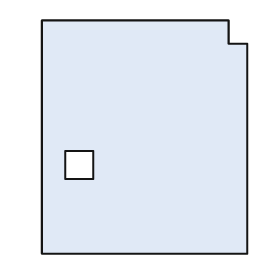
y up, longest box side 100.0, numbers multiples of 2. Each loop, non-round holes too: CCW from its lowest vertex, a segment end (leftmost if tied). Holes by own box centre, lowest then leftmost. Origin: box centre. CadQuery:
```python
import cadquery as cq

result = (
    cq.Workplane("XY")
    .moveTo(-44.0, -50.0)
    .lineTo(44.0, -50.0)
    .lineTo(44.0, 40.0)
    .lineTo(36.0, 40.0)
    .lineTo(36.0, 50.0)
    .lineTo(-44.0, 50.0)
    .close()
    .moveTo(-34.0, -18.0)
    .lineTo(-22.0, -18.0)
    .lineTo(-22.0, -6.0)
    .lineTo(-34.0, -6.0)
    .close()
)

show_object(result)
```